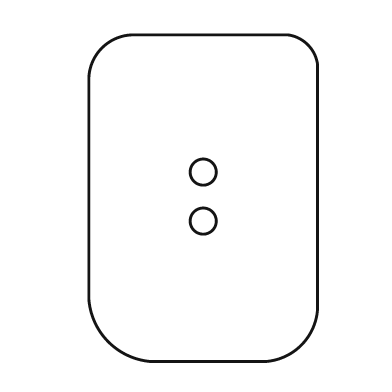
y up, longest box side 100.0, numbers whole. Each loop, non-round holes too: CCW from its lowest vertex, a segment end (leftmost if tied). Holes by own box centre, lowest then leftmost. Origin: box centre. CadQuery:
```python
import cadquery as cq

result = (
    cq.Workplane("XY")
    .moveTo(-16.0, -50.0)
    .lineTo(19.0, -50.0)
    .threePointArc((30.0, -45.0), (35.0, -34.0))
    .lineTo(35.0, 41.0)
    .threePointArc((32.0, 47.0), (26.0, 50.0))
    .lineTo(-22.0, 50.0)
    .threePointArc((-31.0, 46.0), (-35.0, 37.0))
    .lineTo(-35.0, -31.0)
    .threePointArc((-29.0, -44.0), (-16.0, -50.0))
    .close()
    .moveTo(0.0, -7.0)
    .circle(4.0)
    .moveTo(0.0, 8.0)
    .circle(4.0)
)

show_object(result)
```